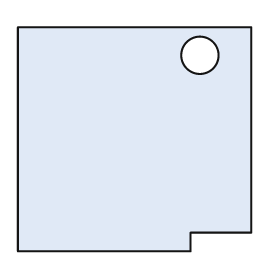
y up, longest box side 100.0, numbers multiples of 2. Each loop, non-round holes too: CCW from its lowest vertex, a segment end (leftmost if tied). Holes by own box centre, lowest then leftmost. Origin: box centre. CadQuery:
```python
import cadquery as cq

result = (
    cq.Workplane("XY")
    .moveTo(-50.0, -48.0)
    .lineTo(24.0, -48.0)
    .lineTo(24.0, -40.0)
    .lineTo(50.0, -40.0)
    .lineTo(50.0, 48.0)
    .lineTo(-50.0, 48.0)
    .close()
    .moveTo(28.0, 36.0)
    .circle(8.0)
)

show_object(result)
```